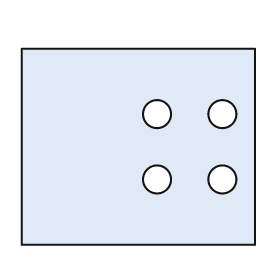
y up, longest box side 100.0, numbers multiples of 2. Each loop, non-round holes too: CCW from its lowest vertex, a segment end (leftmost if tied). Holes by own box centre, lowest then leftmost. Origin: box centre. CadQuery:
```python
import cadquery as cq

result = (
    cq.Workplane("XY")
    .moveTo(-50.0, -42.0)
    .lineTo(50.0, -42.0)
    .lineTo(50.0, 42.0)
    .lineTo(-50.0, 42.0)
    .close()
    .moveTo(8.0, -14.0)
    .circle(6.0)
    .moveTo(36.0, -14.0)
    .circle(6.0)
    .moveTo(8.0, 14.0)
    .circle(6.0)
    .moveTo(36.0, 14.0)
    .circle(6.0)
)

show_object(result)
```